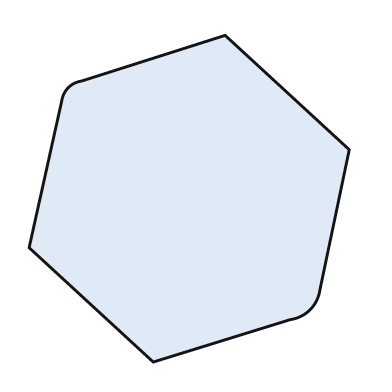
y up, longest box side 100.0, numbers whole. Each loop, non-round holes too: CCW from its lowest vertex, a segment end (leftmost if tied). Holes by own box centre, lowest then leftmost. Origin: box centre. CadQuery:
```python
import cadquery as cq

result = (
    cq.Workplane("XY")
    .moveTo(-11.0, -50.0)
    .lineTo(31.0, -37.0)
    .threePointArc((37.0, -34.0), (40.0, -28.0))
    .lineTo(49.0, 15.0)
    .lineTo(11.0, 50.0)
    .lineTo(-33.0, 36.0)
    .threePointArc((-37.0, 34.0), (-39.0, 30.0))
    .lineTo(-49.0, -15.0)
    .close()
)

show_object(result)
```